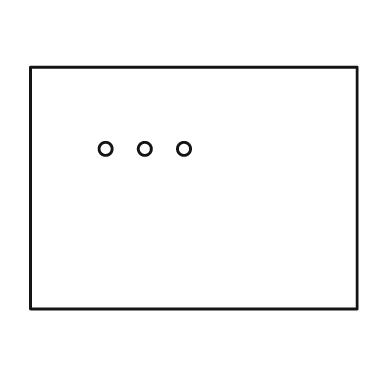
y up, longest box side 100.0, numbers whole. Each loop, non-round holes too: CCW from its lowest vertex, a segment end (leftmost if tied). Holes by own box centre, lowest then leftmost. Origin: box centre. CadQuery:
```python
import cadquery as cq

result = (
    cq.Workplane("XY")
    .moveTo(-50.0, -37.0)
    .lineTo(50.0, -37.0)
    .lineTo(50.0, 37.0)
    .lineTo(-50.0, 37.0)
    .close()
    .moveTo(-27.0, 12.0)
    .circle(2.0)
    .moveTo(-15.0, 12.0)
    .circle(2.0)
    .moveTo(-3.0, 12.0)
    .circle(2.0)
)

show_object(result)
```